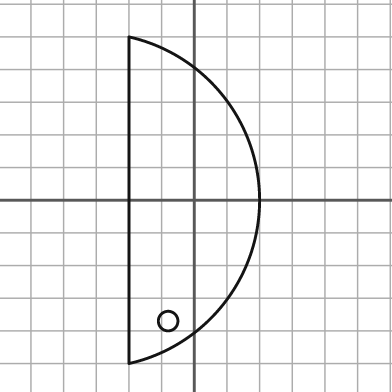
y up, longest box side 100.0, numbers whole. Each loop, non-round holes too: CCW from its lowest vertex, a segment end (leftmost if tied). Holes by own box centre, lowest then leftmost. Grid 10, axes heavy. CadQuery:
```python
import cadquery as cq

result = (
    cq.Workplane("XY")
    .moveTo(-20.0, -50.0)
    .threePointArc((20.0, 0.0), (-20.0, 50.0))
    .close()
    .moveTo(-8.0, -37.0)
    .circle(3.0)
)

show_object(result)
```